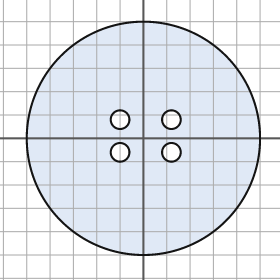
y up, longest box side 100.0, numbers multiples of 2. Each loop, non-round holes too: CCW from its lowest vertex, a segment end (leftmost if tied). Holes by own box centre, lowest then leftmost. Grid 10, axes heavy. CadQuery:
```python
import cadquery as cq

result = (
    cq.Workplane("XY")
    .moveTo(0.0, 0.0)
    .circle(50.0)
    .moveTo(-10.0, -6.0)
    .circle(4.0)
    .moveTo(12.0, -6.0)
    .circle(4.0)
    .moveTo(-10.0, 8.0)
    .circle(4.0)
    .moveTo(12.0, 8.0)
    .circle(4.0)
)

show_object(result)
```